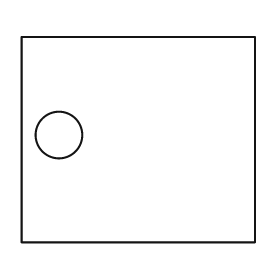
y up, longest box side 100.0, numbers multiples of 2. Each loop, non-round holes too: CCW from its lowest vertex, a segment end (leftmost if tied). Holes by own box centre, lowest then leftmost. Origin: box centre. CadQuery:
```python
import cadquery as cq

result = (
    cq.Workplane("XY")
    .moveTo(-50.0, -44.0)
    .lineTo(50.0, -44.0)
    .lineTo(50.0, 44.0)
    .lineTo(-50.0, 44.0)
    .close()
    .moveTo(-34.0, 2.0)
    .circle(10.0)
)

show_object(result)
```